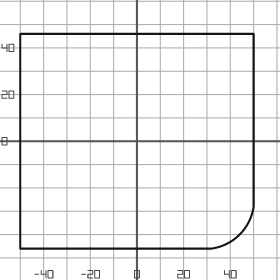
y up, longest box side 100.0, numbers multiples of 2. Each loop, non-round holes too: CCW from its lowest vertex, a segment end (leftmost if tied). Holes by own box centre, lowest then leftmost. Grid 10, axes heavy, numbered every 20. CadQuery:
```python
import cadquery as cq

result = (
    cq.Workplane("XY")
    .moveTo(-50.0, -46.0)
    .lineTo(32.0, -46.0)
    .threePointArc((44.0, -40.0), (50.0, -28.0))
    .lineTo(50.0, 46.0)
    .lineTo(-50.0, 46.0)
    .close()
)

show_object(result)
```